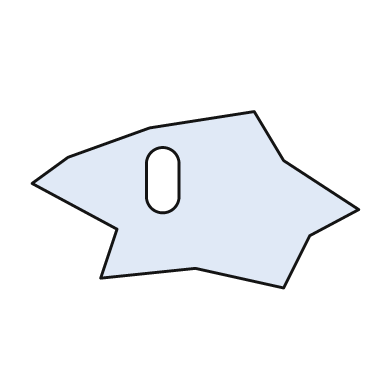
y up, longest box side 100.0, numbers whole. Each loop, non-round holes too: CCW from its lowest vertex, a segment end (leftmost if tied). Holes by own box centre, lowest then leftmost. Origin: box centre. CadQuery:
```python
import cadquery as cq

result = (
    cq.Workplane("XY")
    .moveTo(27.0, -27.0)
    .lineTo(35.0, -11.0)
    .lineTo(50.0, -3.0)
    .lineTo(27.0, 12.0)
    .lineTo(18.0, 27.0)
    .lineTo(-14.0, 22.0)
    .lineTo(-39.0, 13.0)
    .lineTo(-50.0, 5.0)
    .lineTo(-24.0, -9.0)
    .lineTo(-29.0, -24.0)
    .lineTo(0.0, -21.0)
    .close()
    .moveTo(-15.0, 1.0)
    .threePointArc((-10.0, -4.0), (-5.0, 1.0))
    .lineTo(-5.0, 11.0)
    .threePointArc((-10.0, 16.0), (-15.0, 11.0))
    .close()
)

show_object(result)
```